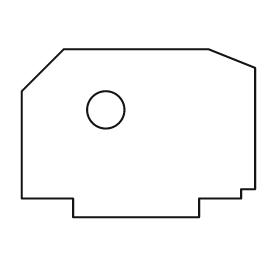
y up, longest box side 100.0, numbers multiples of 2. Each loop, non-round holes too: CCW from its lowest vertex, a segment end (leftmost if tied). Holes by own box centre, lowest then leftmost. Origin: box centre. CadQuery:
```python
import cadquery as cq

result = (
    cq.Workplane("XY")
    .moveTo(-28.0, -36.0)
    .lineTo(26.0, -36.0)
    .lineTo(26.0, -28.0)
    .lineTo(44.0, -28.0)
    .lineTo(44.0, -24.0)
    .lineTo(50.0, -24.0)
    .lineTo(50.0, 28.0)
    .lineTo(30.0, 36.0)
    .lineTo(-32.0, 36.0)
    .lineTo(-50.0, 18.0)
    .lineTo(-50.0, -28.0)
    .lineTo(-28.0, -28.0)
    .close()
    .moveTo(-14.0, 10.0)
    .circle(8.0)
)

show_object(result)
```